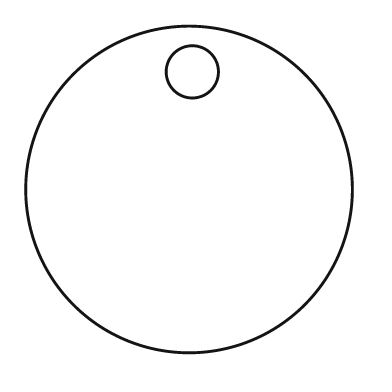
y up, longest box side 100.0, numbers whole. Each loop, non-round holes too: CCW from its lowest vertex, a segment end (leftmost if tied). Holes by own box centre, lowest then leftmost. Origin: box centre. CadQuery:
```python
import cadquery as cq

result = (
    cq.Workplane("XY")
    .moveTo(0.0, 0.0)
    .circle(50.0)
    .moveTo(1.0, 36.0)
    .circle(8.0)
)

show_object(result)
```